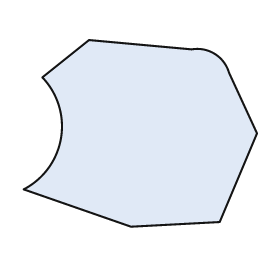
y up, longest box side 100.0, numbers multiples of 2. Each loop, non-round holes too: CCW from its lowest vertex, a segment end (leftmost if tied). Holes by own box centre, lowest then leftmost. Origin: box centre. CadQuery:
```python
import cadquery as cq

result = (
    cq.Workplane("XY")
    .moveTo(-4.0, -40.0)
    .lineTo(34.0, -38.0)
    .lineTo(50.0, 0.0)
    .lineTo(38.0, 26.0)
    .threePointArc((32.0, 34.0), (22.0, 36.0))
    .lineTo(-22.0, 40.0)
    .lineTo(-42.0, 24.0)
    .threePointArc((-34.0, -2.0), (-50.0, -24.0))
    .close()
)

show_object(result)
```